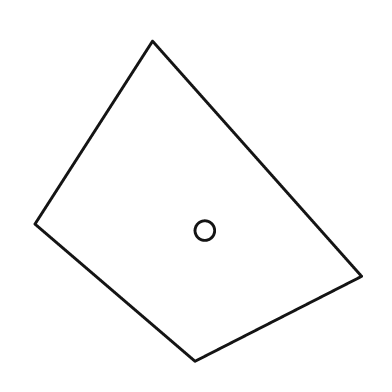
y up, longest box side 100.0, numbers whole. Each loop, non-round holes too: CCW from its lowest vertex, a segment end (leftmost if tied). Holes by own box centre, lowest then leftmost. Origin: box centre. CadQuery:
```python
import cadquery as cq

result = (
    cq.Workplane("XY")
    .moveTo(-1.0, -49.0)
    .lineTo(50.0, -23.0)
    .lineTo(-14.0, 49.0)
    .lineTo(-50.0, -7.0)
    .close()
    .moveTo(2.0, -9.0)
    .circle(3.0)
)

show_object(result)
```